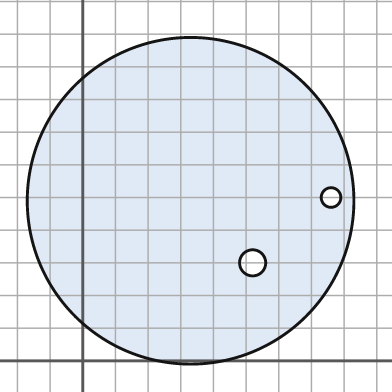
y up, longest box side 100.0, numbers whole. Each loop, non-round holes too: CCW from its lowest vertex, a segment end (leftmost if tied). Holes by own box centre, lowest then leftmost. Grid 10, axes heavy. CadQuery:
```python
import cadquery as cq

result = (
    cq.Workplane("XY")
    .moveTo(33.0, 49.0)
    .circle(50.0)
    .moveTo(52.0, 30.0)
    .circle(4.0)
    .moveTo(76.0, 50.0)
    .circle(3.0)
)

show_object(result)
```